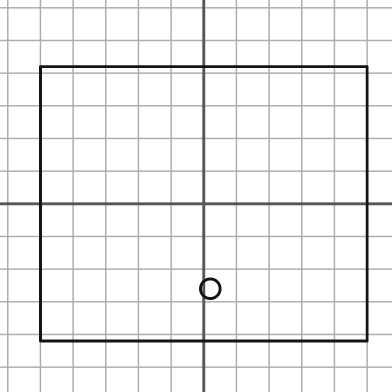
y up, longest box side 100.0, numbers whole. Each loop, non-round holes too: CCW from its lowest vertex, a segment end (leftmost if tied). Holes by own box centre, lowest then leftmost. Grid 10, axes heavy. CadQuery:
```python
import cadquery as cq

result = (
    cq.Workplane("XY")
    .moveTo(-50.0, -42.0)
    .lineTo(50.0, -42.0)
    .lineTo(50.0, 42.0)
    .lineTo(-50.0, 42.0)
    .close()
    .moveTo(2.0, -26.0)
    .circle(3.0)
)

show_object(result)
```